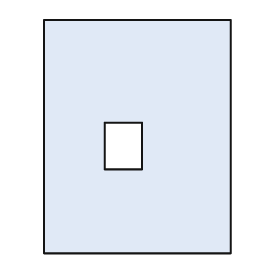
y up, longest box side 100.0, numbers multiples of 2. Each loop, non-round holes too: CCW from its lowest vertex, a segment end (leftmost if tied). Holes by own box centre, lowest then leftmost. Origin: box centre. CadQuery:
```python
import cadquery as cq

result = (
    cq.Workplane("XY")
    .moveTo(-40.0, -50.0)
    .lineTo(40.0, -50.0)
    .lineTo(40.0, 50.0)
    .lineTo(-40.0, 50.0)
    .close()
    .moveTo(-14.0, -14.0)
    .lineTo(2.0, -14.0)
    .lineTo(2.0, 6.0)
    .lineTo(-14.0, 6.0)
    .close()
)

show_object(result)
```